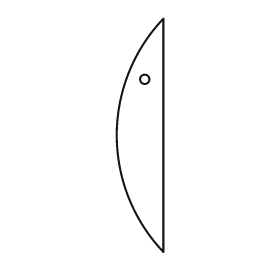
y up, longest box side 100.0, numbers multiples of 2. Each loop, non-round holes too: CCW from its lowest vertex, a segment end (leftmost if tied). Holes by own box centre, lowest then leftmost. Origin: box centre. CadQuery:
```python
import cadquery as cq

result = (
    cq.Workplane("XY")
    .moveTo(10.0, -50.0)
    .lineTo(10.0, 50.0)
    .threePointArc((-10.0, 0.0), (10.0, -50.0))
    .close()
    .moveTo(2.0, 24.0)
    .circle(2.0)
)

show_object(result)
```